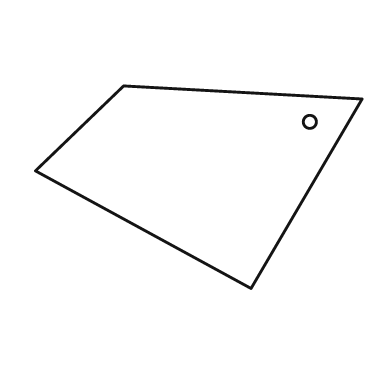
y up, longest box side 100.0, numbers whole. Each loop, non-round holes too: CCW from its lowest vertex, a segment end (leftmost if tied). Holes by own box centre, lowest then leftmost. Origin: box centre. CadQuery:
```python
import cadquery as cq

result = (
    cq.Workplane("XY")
    .moveTo(16.0, -31.0)
    .lineTo(50.0, 27.0)
    .lineTo(-23.0, 31.0)
    .lineTo(-50.0, 5.0)
    .close()
    .moveTo(34.0, 20.0)
    .circle(2.0)
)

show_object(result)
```